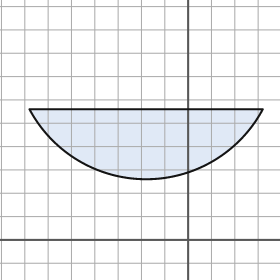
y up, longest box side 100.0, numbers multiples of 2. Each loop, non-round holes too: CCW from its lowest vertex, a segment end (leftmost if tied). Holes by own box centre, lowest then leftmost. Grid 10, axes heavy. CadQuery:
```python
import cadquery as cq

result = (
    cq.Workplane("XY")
    .moveTo(-68.0, 56.0)
    .threePointArc((-18.0, 26.0), (32.0, 56.0))
    .close()
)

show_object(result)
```